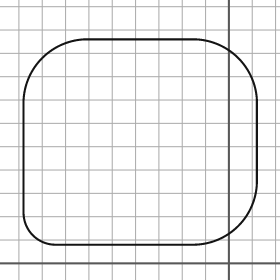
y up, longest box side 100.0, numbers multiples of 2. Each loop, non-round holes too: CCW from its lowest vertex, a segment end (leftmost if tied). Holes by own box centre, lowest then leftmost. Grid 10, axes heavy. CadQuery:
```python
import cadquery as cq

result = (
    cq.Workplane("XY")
    .moveTo(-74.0, 8.0)
    .lineTo(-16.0, 8.0)
    .threePointArc((4.0, 16.0), (12.0, 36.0))
    .lineTo(12.0, 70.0)
    .threePointArc((4.0, 88.0), (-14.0, 96.0))
    .lineTo(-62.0, 96.0)
    .threePointArc((-80.0, 88.0), (-88.0, 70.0))
    .lineTo(-88.0, 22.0)
    .threePointArc((-84.0, 12.0), (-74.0, 8.0))
    .close()
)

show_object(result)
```